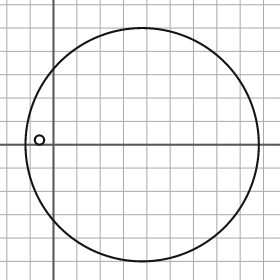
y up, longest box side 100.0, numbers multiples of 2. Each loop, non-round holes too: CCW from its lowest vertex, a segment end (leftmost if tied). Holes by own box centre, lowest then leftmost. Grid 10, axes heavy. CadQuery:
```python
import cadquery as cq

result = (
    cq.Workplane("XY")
    .moveTo(38.0, 0.0)
    .circle(50.0)
    .moveTo(-6.0, 2.0)
    .circle(2.0)
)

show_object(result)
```